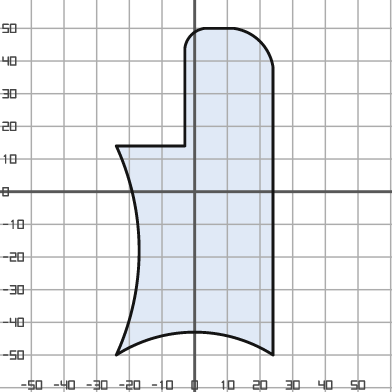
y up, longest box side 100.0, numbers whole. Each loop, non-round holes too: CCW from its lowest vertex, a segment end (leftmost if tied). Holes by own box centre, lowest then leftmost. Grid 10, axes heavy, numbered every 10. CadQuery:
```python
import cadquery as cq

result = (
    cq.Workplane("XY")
    .moveTo(-24.0, -50.0)
    .threePointArc((0.0, -43.0), (24.0, -50.0))
    .lineTo(24.0, 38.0)
    .threePointArc((20.0, 46.0), (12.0, 50.0))
    .lineTo(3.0, 50.0)
    .threePointArc((-1.0, 48.0), (-3.0, 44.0))
    .lineTo(-3.0, 14.0)
    .lineTo(-24.0, 14.0)
    .threePointArc((-17.0, -18.0), (-24.0, -50.0))
    .close()
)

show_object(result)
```